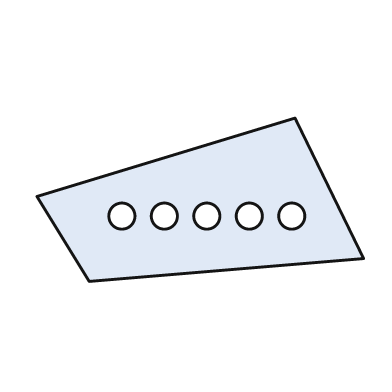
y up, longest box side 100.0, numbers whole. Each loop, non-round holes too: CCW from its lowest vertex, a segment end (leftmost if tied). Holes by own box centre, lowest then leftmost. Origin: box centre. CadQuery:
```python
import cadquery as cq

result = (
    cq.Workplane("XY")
    .moveTo(-34.0, -25.0)
    .lineTo(50.0, -18.0)
    .lineTo(29.0, 25.0)
    .lineTo(-50.0, 1.0)
    .close()
    .moveTo(-24.0, -5.0)
    .circle(4.0)
    .moveTo(-11.0, -5.0)
    .circle(4.0)
    .moveTo(2.0, -5.0)
    .circle(4.0)
    .moveTo(15.0, -5.0)
    .circle(4.0)
    .moveTo(28.0, -5.0)
    .circle(4.0)
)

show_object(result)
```